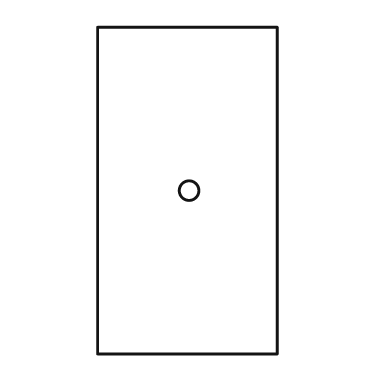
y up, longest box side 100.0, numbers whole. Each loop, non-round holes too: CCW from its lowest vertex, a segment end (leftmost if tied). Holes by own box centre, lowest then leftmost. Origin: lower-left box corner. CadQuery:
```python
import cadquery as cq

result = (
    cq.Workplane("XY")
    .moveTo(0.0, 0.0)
    .lineTo(55.0, 0.0)
    .lineTo(55.0, 100.0)
    .lineTo(0.0, 100.0)
    .close()
    .moveTo(28.0, 50.0)
    .circle(3.0)
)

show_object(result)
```